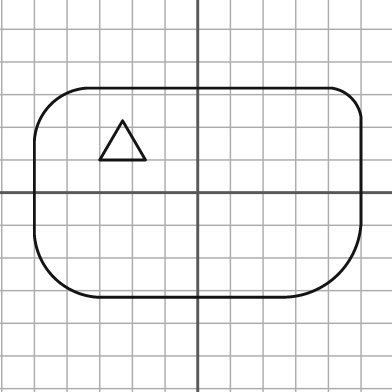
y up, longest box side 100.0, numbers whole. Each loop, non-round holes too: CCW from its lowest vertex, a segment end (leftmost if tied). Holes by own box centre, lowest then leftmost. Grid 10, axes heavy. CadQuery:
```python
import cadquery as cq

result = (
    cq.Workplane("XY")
    .moveTo(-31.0, -32.0)
    .lineTo(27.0, -32.0)
    .threePointArc((43.0, -25.0), (50.0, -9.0))
    .lineTo(50.0, 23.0)
    .threePointArc((47.0, 29.0), (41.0, 32.0))
    .lineTo(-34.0, 32.0)
    .threePointArc((-45.0, 27.0), (-50.0, 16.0))
    .lineTo(-50.0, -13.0)
    .threePointArc((-44.0, -26.0), (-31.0, -32.0))
    .close()
    .moveTo(-30.0, 10.0)
    .lineTo(-16.0, 10.0)
    .lineTo(-23.0, 22.0)
    .close()
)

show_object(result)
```